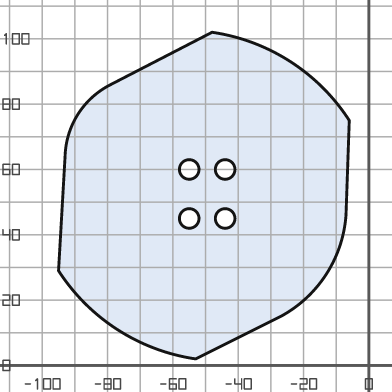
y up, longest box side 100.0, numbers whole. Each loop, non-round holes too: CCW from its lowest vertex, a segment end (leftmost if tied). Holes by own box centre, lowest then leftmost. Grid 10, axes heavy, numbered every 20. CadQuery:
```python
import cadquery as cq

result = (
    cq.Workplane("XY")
    .moveTo(-53.0, 2.0)
    .lineTo(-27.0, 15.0)
    .threePointArc((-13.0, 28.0), (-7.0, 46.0))
    .lineTo(-6.0, 75.0)
    .threePointArc((-24.0, 93.0), (-48.0, 102.0))
    .lineTo(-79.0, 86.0)
    .threePointArc((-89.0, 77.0), (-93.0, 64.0))
    .lineTo(-95.0, 29.0)
    .threePointArc((-77.0, 11.0), (-53.0, 2.0))
    .close()
    .moveTo(-55.0, 45.0)
    .circle(3.0)
    .moveTo(-44.0, 45.0)
    .circle(3.0)
    .moveTo(-55.0, 60.0)
    .circle(3.0)
    .moveTo(-44.0, 60.0)
    .circle(3.0)
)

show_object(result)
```